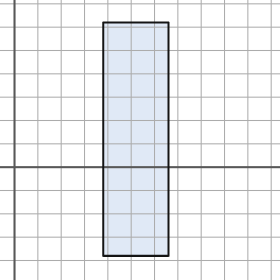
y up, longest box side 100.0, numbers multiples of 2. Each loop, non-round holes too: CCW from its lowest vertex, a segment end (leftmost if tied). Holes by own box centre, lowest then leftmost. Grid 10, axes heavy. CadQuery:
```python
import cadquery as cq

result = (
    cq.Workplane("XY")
    .moveTo(38.0, -38.0)
    .lineTo(66.0, -38.0)
    .lineTo(66.0, 62.0)
    .lineTo(38.0, 62.0)
    .close()
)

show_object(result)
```